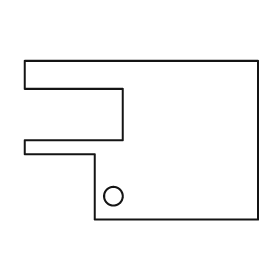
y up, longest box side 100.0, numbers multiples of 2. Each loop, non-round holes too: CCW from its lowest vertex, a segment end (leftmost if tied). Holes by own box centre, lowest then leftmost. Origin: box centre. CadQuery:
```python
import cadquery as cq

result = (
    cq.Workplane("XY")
    .moveTo(-20.0, -34.0)
    .lineTo(50.0, -34.0)
    .lineTo(50.0, 34.0)
    .lineTo(-50.0, 34.0)
    .lineTo(-50.0, 22.0)
    .lineTo(-8.0, 22.0)
    .lineTo(-8.0, 0.0)
    .lineTo(-50.0, 0.0)
    .lineTo(-50.0, -6.0)
    .lineTo(-20.0, -6.0)
    .close()
    .moveTo(-12.0, -24.0)
    .circle(4.0)
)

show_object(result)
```